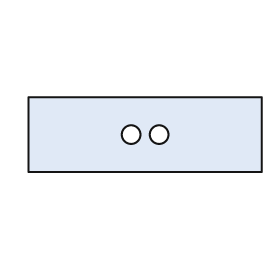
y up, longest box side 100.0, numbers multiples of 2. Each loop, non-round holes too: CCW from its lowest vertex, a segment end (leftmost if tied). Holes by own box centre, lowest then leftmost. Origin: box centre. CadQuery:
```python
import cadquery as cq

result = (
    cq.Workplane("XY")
    .moveTo(-50.0, -16.0)
    .lineTo(50.0, -16.0)
    .lineTo(50.0, 16.0)
    .lineTo(-50.0, 16.0)
    .close()
    .moveTo(-6.0, 0.0)
    .circle(4.0)
    .moveTo(6.0, 0.0)
    .circle(4.0)
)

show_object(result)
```